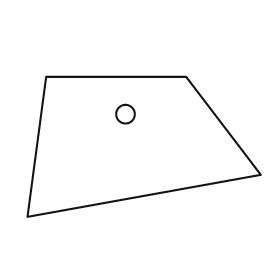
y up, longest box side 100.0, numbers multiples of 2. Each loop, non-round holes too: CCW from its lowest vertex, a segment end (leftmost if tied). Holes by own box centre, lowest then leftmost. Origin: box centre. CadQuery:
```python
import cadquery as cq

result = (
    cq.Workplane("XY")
    .moveTo(-50.0, -30.0)
    .lineTo(50.0, -12.0)
    .lineTo(18.0, 30.0)
    .lineTo(-42.0, 30.0)
    .close()
    .moveTo(-8.0, 14.0)
    .circle(4.0)
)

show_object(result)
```